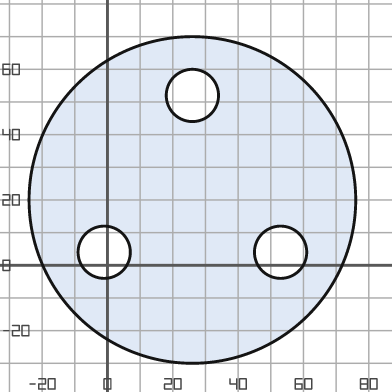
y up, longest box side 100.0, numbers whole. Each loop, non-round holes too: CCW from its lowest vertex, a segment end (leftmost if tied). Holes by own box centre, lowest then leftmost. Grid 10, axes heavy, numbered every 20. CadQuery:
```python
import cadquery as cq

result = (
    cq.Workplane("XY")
    .moveTo(26.0, 20.0)
    .circle(50.0)
    .moveTo(-1.0, 4.0)
    .circle(8.0)
    .moveTo(53.0, 4.0)
    .circle(8.0)
    .moveTo(26.0, 52.0)
    .circle(8.0)
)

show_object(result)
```